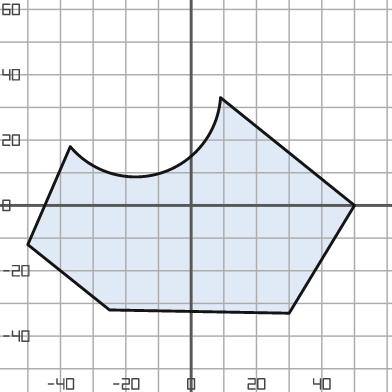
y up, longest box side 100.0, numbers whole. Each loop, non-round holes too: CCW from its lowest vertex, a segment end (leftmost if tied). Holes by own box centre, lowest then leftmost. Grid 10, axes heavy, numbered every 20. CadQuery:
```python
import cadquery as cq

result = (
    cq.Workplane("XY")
    .moveTo(30.0, -33.0)
    .lineTo(50.0, 0.0)
    .lineTo(9.0, 33.0)
    .threePointArc((-9.0, 10.0), (-37.0, 18.0))
    .lineTo(-50.0, -12.0)
    .lineTo(-25.0, -32.0)
    .close()
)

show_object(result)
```